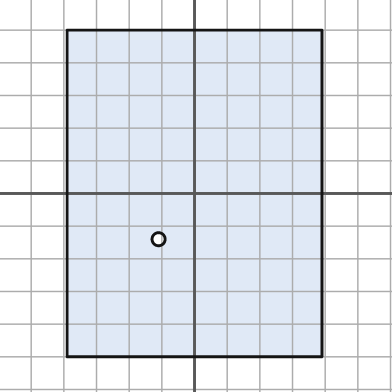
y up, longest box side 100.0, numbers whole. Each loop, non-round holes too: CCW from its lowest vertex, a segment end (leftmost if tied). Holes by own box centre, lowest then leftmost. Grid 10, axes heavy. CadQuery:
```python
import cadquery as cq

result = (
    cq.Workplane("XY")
    .moveTo(-39.0, -50.0)
    .lineTo(39.0, -50.0)
    .lineTo(39.0, 50.0)
    .lineTo(-39.0, 50.0)
    .close()
    .moveTo(-11.0, -14.0)
    .circle(2.0)
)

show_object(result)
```